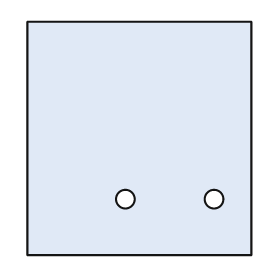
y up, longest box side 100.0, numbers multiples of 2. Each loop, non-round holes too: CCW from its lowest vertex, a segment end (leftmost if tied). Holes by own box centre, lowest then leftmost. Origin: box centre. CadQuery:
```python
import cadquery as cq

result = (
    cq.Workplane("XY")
    .moveTo(-48.0, -50.0)
    .lineTo(48.0, -50.0)
    .lineTo(48.0, 50.0)
    .lineTo(-48.0, 50.0)
    .close()
    .moveTo(-6.0, -26.0)
    .circle(4.0)
    .moveTo(32.0, -26.0)
    .circle(4.0)
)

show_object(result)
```